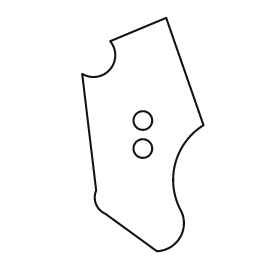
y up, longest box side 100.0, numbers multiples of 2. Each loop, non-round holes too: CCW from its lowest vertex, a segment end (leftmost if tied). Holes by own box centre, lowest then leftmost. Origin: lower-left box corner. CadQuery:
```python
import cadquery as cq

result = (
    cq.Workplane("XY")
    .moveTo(32.0, 0.0)
    .threePointArc((42.0, 6.0), (42.0, 18.0))
    .threePointArc((40.0, 38.0), (52.0, 54.0))
    .lineTo(36.0, 100.0)
    .lineTo(12.0, 90.0)
    .threePointArc((12.0, 78.0), (0.0, 76.0))
    .lineTo(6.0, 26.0)
    .threePointArc((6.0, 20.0), (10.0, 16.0))
    .close()
    .moveTo(26.0, 44.0)
    .circle(4.0)
    .moveTo(26.0, 56.0)
    .circle(4.0)
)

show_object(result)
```